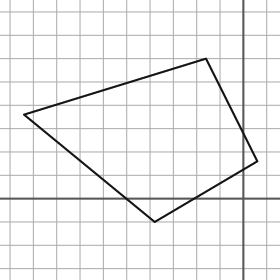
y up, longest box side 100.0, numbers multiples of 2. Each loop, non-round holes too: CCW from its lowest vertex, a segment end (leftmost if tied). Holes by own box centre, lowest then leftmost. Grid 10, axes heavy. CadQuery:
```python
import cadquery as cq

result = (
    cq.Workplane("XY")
    .moveTo(-38.0, -10.0)
    .lineTo(6.0, 16.0)
    .lineTo(-16.0, 60.0)
    .lineTo(-94.0, 36.0)
    .close()
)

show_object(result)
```